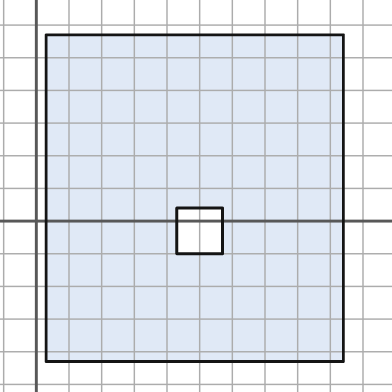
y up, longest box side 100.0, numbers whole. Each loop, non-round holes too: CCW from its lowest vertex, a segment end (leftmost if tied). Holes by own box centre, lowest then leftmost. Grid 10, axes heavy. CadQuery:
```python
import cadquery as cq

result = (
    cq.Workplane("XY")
    .moveTo(3.0, -43.0)
    .lineTo(94.0, -43.0)
    .lineTo(94.0, 57.0)
    .lineTo(3.0, 57.0)
    .close()
    .moveTo(43.0, -10.0)
    .lineTo(57.0, -10.0)
    .lineTo(57.0, 4.0)
    .lineTo(43.0, 4.0)
    .close()
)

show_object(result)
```